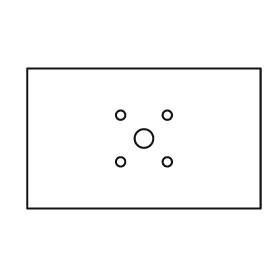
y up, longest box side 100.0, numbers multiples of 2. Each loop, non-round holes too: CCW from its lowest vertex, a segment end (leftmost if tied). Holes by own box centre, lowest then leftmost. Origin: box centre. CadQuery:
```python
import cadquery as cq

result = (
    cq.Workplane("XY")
    .moveTo(-50.0, -30.0)
    .lineTo(50.0, -30.0)
    .lineTo(50.0, 30.0)
    .lineTo(-50.0, 30.0)
    .close()
    .moveTo(-10.0, -10.0)
    .circle(2.0)
    .moveTo(10.0, -10.0)
    .circle(2.0)
    .moveTo(0.0, 0.0)
    .circle(4.0)
    .moveTo(-10.0, 10.0)
    .circle(2.0)
    .moveTo(10.0, 10.0)
    .circle(2.0)
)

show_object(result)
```